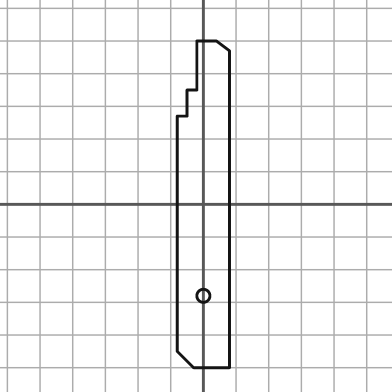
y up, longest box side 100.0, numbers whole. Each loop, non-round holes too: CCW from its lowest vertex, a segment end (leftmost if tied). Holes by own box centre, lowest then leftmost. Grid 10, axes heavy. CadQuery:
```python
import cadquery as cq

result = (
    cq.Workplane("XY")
    .moveTo(-3.0, -50.0)
    .lineTo(8.0, -50.0)
    .lineTo(8.0, 47.0)
    .lineTo(4.0, 50.0)
    .lineTo(-2.0, 50.0)
    .lineTo(-2.0, 35.0)
    .lineTo(-5.0, 35.0)
    .lineTo(-5.0, 27.0)
    .lineTo(-8.0, 27.0)
    .lineTo(-8.0, -45.0)
    .close()
    .moveTo(0.0, -28.0)
    .circle(2.0)
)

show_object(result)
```